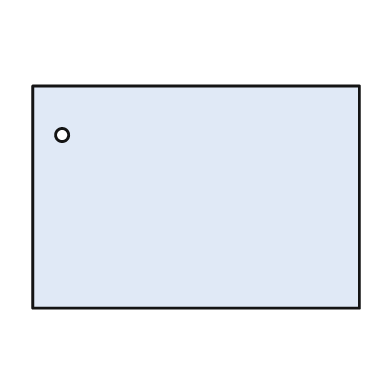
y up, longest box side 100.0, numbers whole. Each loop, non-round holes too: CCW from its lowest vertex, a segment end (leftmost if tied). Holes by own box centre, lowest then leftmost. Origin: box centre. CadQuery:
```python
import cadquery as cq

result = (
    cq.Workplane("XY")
    .moveTo(-50.0, -34.0)
    .lineTo(50.0, -34.0)
    .lineTo(50.0, 34.0)
    .lineTo(-50.0, 34.0)
    .close()
    .moveTo(-41.0, 19.0)
    .circle(2.0)
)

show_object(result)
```